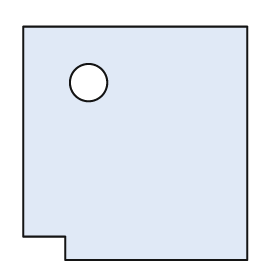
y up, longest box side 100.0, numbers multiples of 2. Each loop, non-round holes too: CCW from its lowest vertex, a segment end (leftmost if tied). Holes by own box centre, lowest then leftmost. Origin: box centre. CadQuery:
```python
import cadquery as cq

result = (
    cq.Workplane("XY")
    .moveTo(-30.0, -50.0)
    .lineTo(48.0, -50.0)
    .lineTo(48.0, 50.0)
    .lineTo(-48.0, 50.0)
    .lineTo(-48.0, -40.0)
    .lineTo(-30.0, -40.0)
    .close()
    .moveTo(-20.0, 26.0)
    .circle(8.0)
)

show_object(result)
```